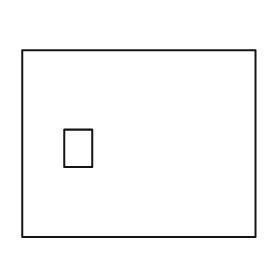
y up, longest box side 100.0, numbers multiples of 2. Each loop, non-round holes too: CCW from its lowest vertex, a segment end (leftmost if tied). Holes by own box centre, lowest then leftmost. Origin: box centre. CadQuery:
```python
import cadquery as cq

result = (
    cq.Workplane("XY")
    .moveTo(-50.0, -40.0)
    .lineTo(50.0, -40.0)
    .lineTo(50.0, 40.0)
    .lineTo(-50.0, 40.0)
    .close()
    .moveTo(-32.0, -10.0)
    .lineTo(-20.0, -10.0)
    .lineTo(-20.0, 6.0)
    .lineTo(-32.0, 6.0)
    .close()
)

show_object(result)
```